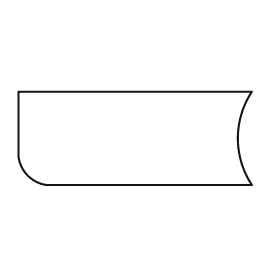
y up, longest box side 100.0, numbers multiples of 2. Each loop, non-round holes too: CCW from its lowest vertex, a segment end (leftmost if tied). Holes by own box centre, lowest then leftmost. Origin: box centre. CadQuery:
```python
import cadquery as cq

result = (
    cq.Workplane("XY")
    .moveTo(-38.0, -20.0)
    .lineTo(50.0, -20.0)
    .threePointArc((44.0, 0.0), (50.0, 20.0))
    .lineTo(-50.0, 20.0)
    .lineTo(-50.0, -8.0)
    .threePointArc((-46.0, -16.0), (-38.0, -20.0))
    .close()
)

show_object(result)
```